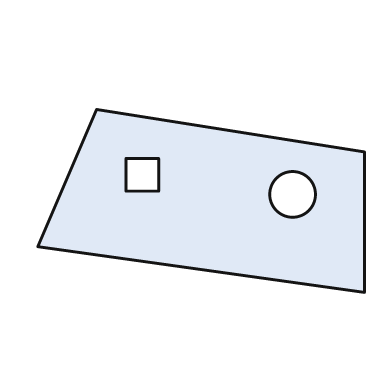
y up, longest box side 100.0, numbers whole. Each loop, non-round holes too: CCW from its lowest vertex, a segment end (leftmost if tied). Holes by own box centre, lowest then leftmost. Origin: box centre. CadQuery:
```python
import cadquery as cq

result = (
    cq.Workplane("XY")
    .moveTo(50.0, -28.0)
    .lineTo(50.0, 15.0)
    .lineTo(-32.0, 28.0)
    .lineTo(-50.0, -14.0)
    .close()
    .moveTo(28.0, 2.0)
    .circle(7.0)
    .moveTo(-23.0, 3.0)
    .lineTo(-13.0, 3.0)
    .lineTo(-13.0, 13.0)
    .lineTo(-23.0, 13.0)
    .close()
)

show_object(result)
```